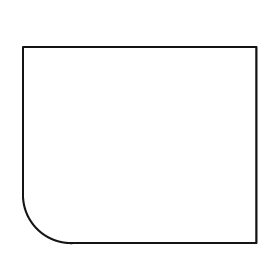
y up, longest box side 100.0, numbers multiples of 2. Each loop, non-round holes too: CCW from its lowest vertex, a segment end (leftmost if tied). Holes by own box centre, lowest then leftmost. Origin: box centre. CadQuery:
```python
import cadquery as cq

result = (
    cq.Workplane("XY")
    .moveTo(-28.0, -42.0)
    .lineTo(50.0, -42.0)
    .lineTo(50.0, 42.0)
    .lineTo(-50.0, 42.0)
    .lineTo(-50.0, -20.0)
    .threePointArc((-44.0, -36.0), (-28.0, -42.0))
    .close()
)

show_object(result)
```